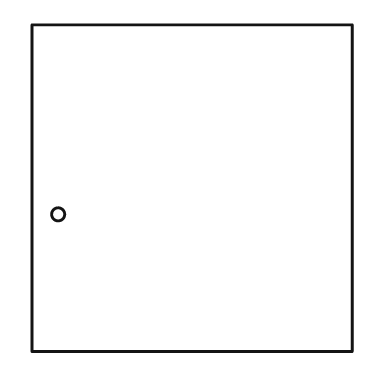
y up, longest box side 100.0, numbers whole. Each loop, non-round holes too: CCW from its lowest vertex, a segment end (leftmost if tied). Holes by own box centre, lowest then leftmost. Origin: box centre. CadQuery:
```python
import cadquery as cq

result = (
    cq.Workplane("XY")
    .moveTo(-49.0, -50.0)
    .lineTo(49.0, -50.0)
    .lineTo(49.0, 50.0)
    .lineTo(-49.0, 50.0)
    .close()
    .moveTo(-41.0, -8.0)
    .circle(2.0)
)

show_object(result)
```